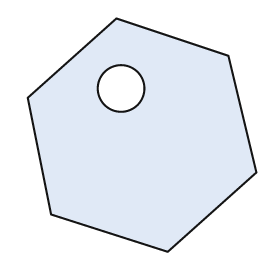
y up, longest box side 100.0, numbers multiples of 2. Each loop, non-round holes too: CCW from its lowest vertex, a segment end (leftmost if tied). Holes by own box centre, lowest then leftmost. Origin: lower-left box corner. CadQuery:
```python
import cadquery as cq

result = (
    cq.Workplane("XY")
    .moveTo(60.0, 0.0)
    .lineTo(98.0, 34.0)
    .lineTo(86.0, 84.0)
    .lineTo(38.0, 100.0)
    .lineTo(0.0, 66.0)
    .lineTo(10.0, 16.0)
    .close()
    .moveTo(40.0, 70.0)
    .circle(10.0)
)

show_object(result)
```